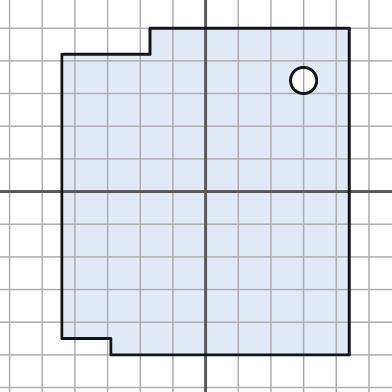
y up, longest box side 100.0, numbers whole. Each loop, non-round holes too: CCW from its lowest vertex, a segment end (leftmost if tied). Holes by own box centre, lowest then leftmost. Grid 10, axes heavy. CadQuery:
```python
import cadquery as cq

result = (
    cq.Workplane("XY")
    .moveTo(-29.0, -50.0)
    .lineTo(44.0, -50.0)
    .lineTo(44.0, 50.0)
    .lineTo(-17.0, 50.0)
    .lineTo(-17.0, 42.0)
    .lineTo(-44.0, 42.0)
    .lineTo(-44.0, -45.0)
    .lineTo(-29.0, -45.0)
    .close()
    .moveTo(30.0, 34.0)
    .circle(4.0)
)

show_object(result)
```